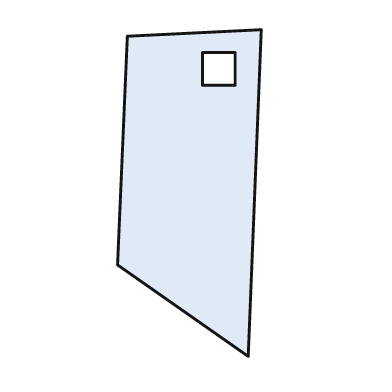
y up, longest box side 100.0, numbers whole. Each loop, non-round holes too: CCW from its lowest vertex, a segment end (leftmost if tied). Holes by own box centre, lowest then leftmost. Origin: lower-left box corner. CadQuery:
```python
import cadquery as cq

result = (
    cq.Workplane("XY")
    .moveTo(40.0, 0.0)
    .lineTo(44.0, 100.0)
    .lineTo(3.0, 98.0)
    .lineTo(0.0, 28.0)
    .close()
    .moveTo(26.0, 83.0)
    .lineTo(36.0, 83.0)
    .lineTo(36.0, 93.0)
    .lineTo(26.0, 93.0)
    .close()
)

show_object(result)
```